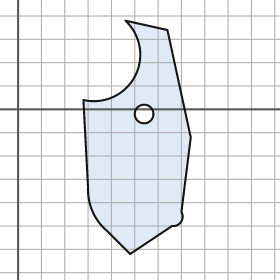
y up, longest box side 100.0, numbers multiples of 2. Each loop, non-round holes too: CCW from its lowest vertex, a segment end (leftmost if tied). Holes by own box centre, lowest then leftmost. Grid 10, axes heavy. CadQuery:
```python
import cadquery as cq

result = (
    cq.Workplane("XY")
    .moveTo(48.0, -62.0)
    .lineTo(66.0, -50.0)
    .threePointArc((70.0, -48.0), (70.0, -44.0))
    .lineTo(74.0, -12.0)
    .lineTo(64.0, 34.0)
    .lineTo(46.0, 38.0)
    .threePointArc((50.0, 14.0), (28.0, 4.0))
    .lineTo(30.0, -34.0)
    .threePointArc((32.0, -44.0), (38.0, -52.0))
    .close()
    .moveTo(54.0, -2.0)
    .circle(4.0)
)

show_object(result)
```